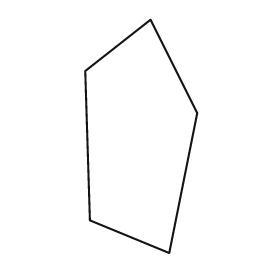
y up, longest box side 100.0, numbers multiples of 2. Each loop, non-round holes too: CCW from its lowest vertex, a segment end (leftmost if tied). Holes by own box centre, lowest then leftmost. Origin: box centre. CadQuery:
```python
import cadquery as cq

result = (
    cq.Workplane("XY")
    .moveTo(12.0, -50.0)
    .lineTo(24.0, 10.0)
    .lineTo(4.0, 50.0)
    .lineTo(-24.0, 28.0)
    .lineTo(-22.0, -36.0)
    .close()
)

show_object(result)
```